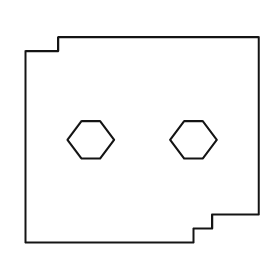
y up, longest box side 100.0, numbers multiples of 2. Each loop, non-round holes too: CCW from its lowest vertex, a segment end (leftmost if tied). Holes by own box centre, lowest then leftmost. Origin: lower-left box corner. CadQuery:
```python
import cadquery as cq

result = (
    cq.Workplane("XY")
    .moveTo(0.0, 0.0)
    .lineTo(72.0, 0.0)
    .lineTo(72.0, 6.0)
    .lineTo(80.0, 6.0)
    .lineTo(80.0, 12.0)
    .lineTo(100.0, 12.0)
    .lineTo(100.0, 88.0)
    .lineTo(14.0, 88.0)
    .lineTo(14.0, 82.0)
    .lineTo(0.0, 82.0)
    .close()
    .moveTo(24.0, 36.0)
    .lineTo(32.0, 36.0)
    .lineTo(38.0, 44.0)
    .lineTo(32.0, 52.0)
    .lineTo(24.0, 52.0)
    .lineTo(18.0, 44.0)
    .close()
    .moveTo(68.0, 36.0)
    .lineTo(76.0, 36.0)
    .lineTo(82.0, 44.0)
    .lineTo(76.0, 52.0)
    .lineTo(68.0, 52.0)
    .lineTo(62.0, 44.0)
    .close()
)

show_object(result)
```